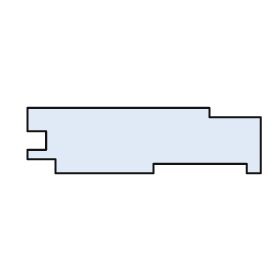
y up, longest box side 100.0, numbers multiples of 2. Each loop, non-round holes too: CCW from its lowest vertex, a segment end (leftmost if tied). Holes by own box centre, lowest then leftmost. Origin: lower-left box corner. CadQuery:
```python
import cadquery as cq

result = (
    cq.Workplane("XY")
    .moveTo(12.0, 0.0)
    .lineTo(54.0, 0.0)
    .lineTo(54.0, 4.0)
    .lineTo(94.0, 4.0)
    .lineTo(94.0, 0.0)
    .lineTo(100.0, 0.0)
    .lineTo(100.0, 24.0)
    .lineTo(78.0, 24.0)
    .lineTo(78.0, 28.0)
    .lineTo(0.0, 28.0)
    .lineTo(0.0, 18.0)
    .lineTo(8.0, 18.0)
    .lineTo(8.0, 10.0)
    .lineTo(0.0, 10.0)
    .lineTo(0.0, 6.0)
    .lineTo(12.0, 6.0)
    .close()
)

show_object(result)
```